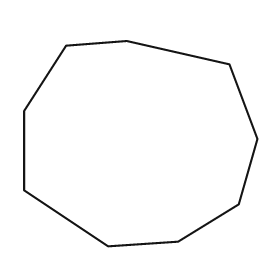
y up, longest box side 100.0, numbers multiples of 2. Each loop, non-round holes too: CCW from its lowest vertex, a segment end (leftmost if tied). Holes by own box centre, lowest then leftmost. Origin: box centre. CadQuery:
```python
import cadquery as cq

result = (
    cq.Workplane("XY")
    .moveTo(-14.0, -44.0)
    .lineTo(16.0, -42.0)
    .lineTo(42.0, -26.0)
    .lineTo(50.0, 2.0)
    .lineTo(38.0, 34.0)
    .lineTo(-6.0, 44.0)
    .lineTo(-32.0, 42.0)
    .lineTo(-50.0, 14.0)
    .lineTo(-50.0, -20.0)
    .close()
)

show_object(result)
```